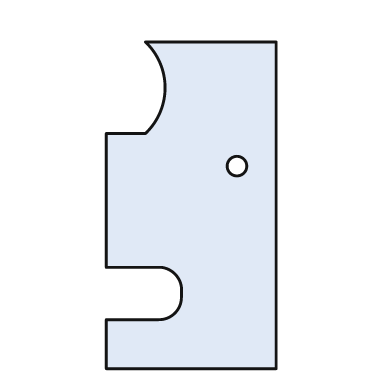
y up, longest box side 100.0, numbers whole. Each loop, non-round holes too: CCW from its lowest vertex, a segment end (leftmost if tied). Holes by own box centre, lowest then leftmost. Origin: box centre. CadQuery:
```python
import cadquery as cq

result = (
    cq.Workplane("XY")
    .moveTo(-26.0, -50.0)
    .lineTo(26.0, -50.0)
    .lineTo(26.0, 50.0)
    .lineTo(-14.0, 50.0)
    .threePointArc((-8.0, 36.0), (-14.0, 22.0))
    .lineTo(-26.0, 22.0)
    .lineTo(-26.0, -19.0)
    .lineTo(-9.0, -19.0)
    .threePointArc((-5.0, -21.0), (-3.0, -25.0))
    .lineTo(-3.0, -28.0)
    .threePointArc((-5.0, -33.0), (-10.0, -35.0))
    .lineTo(-26.0, -35.0)
    .close()
    .moveTo(14.0, 12.0)
    .circle(3.0)
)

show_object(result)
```